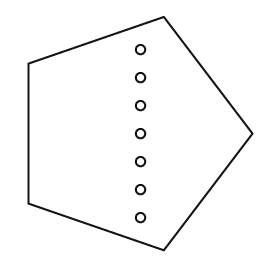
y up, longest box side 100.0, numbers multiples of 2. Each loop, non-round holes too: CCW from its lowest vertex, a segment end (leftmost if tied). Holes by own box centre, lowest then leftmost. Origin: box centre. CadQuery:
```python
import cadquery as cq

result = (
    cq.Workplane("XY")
    .moveTo(10.0, -50.0)
    .lineTo(48.0, 0.0)
    .lineTo(10.0, 50.0)
    .lineTo(-48.0, 30.0)
    .lineTo(-48.0, -30.0)
    .close()
    .moveTo(0.0, -36.0)
    .circle(2.0)
    .moveTo(0.0, -24.0)
    .circle(2.0)
    .moveTo(0.0, -12.0)
    .circle(2.0)
    .moveTo(0.0, 0.0)
    .circle(2.0)
    .moveTo(0.0, 12.0)
    .circle(2.0)
    .moveTo(0.0, 24.0)
    .circle(2.0)
    .moveTo(0.0, 36.0)
    .circle(2.0)
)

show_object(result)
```